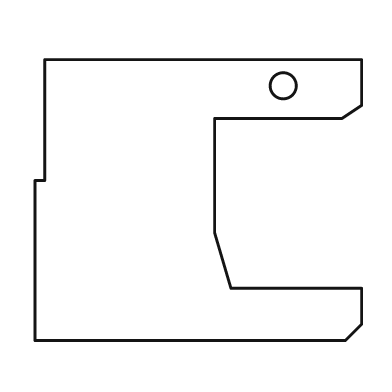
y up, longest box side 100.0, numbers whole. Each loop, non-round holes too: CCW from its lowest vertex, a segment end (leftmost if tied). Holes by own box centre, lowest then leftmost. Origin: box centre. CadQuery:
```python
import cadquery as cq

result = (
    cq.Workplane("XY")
    .moveTo(-50.0, -43.0)
    .lineTo(45.0, -43.0)
    .lineTo(50.0, -38.0)
    .lineTo(50.0, -27.0)
    .lineTo(10.0, -27.0)
    .lineTo(5.0, -10.0)
    .lineTo(5.0, 25.0)
    .lineTo(44.0, 25.0)
    .lineTo(50.0, 29.0)
    .lineTo(50.0, 43.0)
    .lineTo(-47.0, 43.0)
    .lineTo(-47.0, 6.0)
    .lineTo(-50.0, 6.0)
    .close()
    .moveTo(26.0, 35.0)
    .circle(4.0)
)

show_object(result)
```